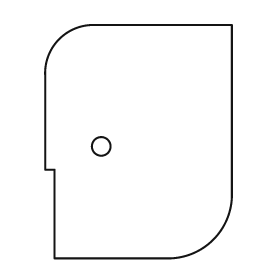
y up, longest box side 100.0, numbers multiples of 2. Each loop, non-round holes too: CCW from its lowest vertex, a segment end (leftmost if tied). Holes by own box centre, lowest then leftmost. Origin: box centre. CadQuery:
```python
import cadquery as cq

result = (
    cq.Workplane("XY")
    .moveTo(-36.0, -50.0)
    .lineTo(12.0, -50.0)
    .threePointArc((32.0, -42.0), (40.0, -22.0))
    .lineTo(40.0, 50.0)
    .lineTo(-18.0, 50.0)
    .threePointArc((-34.0, 44.0), (-40.0, 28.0))
    .lineTo(-40.0, -12.0)
    .lineTo(-36.0, -12.0)
    .close()
    .moveTo(-16.0, -2.0)
    .circle(4.0)
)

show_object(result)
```